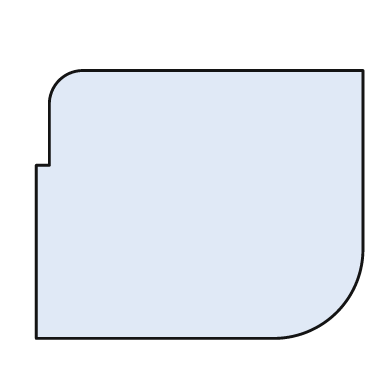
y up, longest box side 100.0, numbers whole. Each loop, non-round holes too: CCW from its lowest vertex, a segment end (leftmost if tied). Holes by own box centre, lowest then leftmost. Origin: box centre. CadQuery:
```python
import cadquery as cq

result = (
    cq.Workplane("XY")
    .moveTo(-50.0, -41.0)
    .lineTo(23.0, -41.0)
    .threePointArc((42.0, -33.0), (50.0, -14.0))
    .lineTo(50.0, 41.0)
    .lineTo(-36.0, 41.0)
    .threePointArc((-43.0, 38.0), (-46.0, 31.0))
    .lineTo(-46.0, 12.0)
    .lineTo(-50.0, 12.0)
    .close()
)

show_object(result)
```